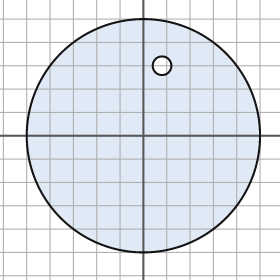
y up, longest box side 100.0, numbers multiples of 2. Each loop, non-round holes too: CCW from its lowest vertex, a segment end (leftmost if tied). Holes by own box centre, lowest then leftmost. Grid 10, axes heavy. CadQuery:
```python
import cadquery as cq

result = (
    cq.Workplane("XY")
    .moveTo(0.0, 0.0)
    .circle(50.0)
    .moveTo(8.0, 30.0)
    .circle(4.0)
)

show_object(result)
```